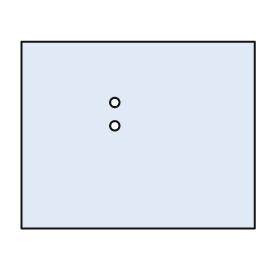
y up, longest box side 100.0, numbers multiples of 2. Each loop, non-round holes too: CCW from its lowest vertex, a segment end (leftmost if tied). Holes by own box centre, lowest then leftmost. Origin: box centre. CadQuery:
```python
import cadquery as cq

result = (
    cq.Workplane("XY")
    .moveTo(-50.0, -40.0)
    .lineTo(50.0, -40.0)
    .lineTo(50.0, 40.0)
    .lineTo(-50.0, 40.0)
    .close()
    .moveTo(-10.0, 4.0)
    .circle(2.0)
    .moveTo(-10.0, 14.0)
    .circle(2.0)
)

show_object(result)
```